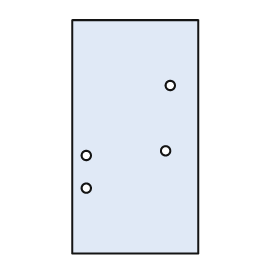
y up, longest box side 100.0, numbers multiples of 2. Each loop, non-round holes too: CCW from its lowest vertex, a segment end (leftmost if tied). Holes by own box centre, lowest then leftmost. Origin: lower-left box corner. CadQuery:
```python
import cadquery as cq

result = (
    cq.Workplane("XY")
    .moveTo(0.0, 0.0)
    .lineTo(54.0, 0.0)
    .lineTo(54.0, 100.0)
    .lineTo(0.0, 100.0)
    .close()
    .moveTo(6.0, 28.0)
    .circle(2.0)
    .moveTo(6.0, 42.0)
    .circle(2.0)
    .moveTo(40.0, 44.0)
    .circle(2.0)
    .moveTo(42.0, 72.0)
    .circle(2.0)
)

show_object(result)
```